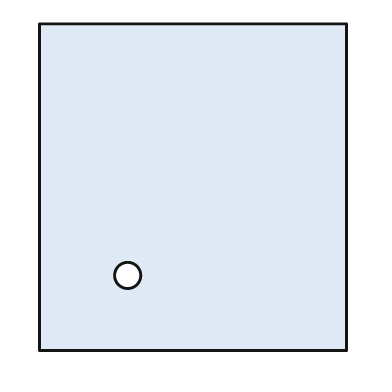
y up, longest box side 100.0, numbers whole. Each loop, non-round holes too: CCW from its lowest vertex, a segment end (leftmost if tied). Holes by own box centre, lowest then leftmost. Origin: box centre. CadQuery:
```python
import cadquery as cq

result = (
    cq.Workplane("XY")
    .moveTo(-47.0, -50.0)
    .lineTo(47.0, -50.0)
    .lineTo(47.0, 50.0)
    .lineTo(-47.0, 50.0)
    .close()
    .moveTo(-20.0, -27.0)
    .circle(4.0)
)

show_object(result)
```